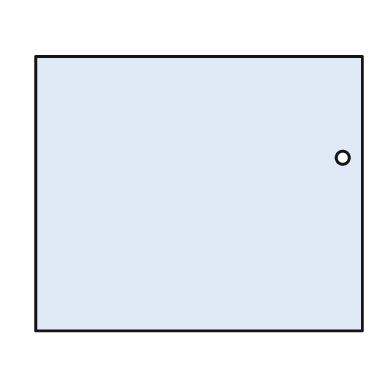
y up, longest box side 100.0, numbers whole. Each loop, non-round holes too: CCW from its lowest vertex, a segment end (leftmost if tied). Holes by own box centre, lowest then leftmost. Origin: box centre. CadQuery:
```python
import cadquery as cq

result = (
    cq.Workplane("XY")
    .moveTo(-50.0, -42.0)
    .lineTo(50.0, -42.0)
    .lineTo(50.0, 42.0)
    .lineTo(-50.0, 42.0)
    .close()
    .moveTo(44.0, 11.0)
    .circle(2.0)
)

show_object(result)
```